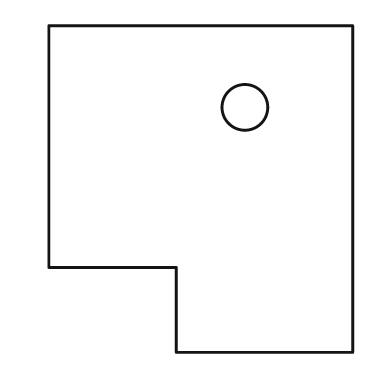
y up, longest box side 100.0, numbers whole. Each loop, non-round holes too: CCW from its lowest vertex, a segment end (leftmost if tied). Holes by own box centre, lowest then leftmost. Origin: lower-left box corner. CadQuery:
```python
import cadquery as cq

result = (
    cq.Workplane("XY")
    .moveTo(39.0, 0.0)
    .lineTo(93.0, 0.0)
    .lineTo(93.0, 100.0)
    .lineTo(0.0, 100.0)
    .lineTo(0.0, 26.0)
    .lineTo(39.0, 26.0)
    .close()
    .moveTo(60.0, 75.0)
    .circle(7.0)
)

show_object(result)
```